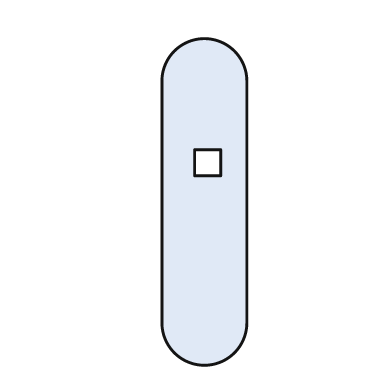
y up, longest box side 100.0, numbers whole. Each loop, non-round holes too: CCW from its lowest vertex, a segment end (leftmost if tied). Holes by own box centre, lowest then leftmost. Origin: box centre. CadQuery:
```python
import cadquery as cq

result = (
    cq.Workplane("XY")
    .moveTo(-13.0, -37.0)
    .threePointArc((0.0, -50.0), (13.0, -37.0))
    .lineTo(13.0, 37.0)
    .threePointArc((0.0, 50.0), (-13.0, 37.0))
    .close()
    .moveTo(-3.0, 8.0)
    .lineTo(5.0, 8.0)
    .lineTo(5.0, 16.0)
    .lineTo(-3.0, 16.0)
    .close()
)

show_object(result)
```